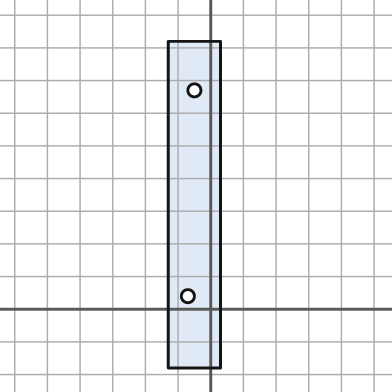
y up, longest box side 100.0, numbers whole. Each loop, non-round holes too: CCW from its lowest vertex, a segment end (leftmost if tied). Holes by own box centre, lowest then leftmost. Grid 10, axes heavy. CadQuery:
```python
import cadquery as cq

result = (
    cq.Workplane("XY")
    .moveTo(-13.0, -18.0)
    .lineTo(3.0, -18.0)
    .lineTo(3.0, 82.0)
    .lineTo(-13.0, 82.0)
    .close()
    .moveTo(-7.0, 4.0)
    .circle(2.0)
    .moveTo(-5.0, 67.0)
    .circle(2.0)
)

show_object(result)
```